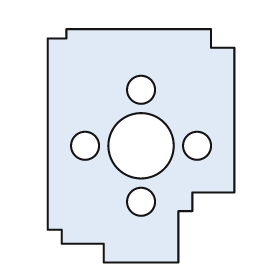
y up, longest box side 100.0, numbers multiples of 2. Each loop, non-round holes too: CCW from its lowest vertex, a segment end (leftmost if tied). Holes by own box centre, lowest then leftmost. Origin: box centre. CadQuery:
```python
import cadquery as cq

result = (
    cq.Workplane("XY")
    .moveTo(-16.0, -50.0)
    .lineTo(16.0, -50.0)
    .lineTo(16.0, -28.0)
    .lineTo(22.0, -28.0)
    .lineTo(22.0, -20.0)
    .lineTo(40.0, -20.0)
    .lineTo(40.0, 42.0)
    .lineTo(30.0, 42.0)
    .lineTo(30.0, 50.0)
    .lineTo(-32.0, 50.0)
    .lineTo(-32.0, 46.0)
    .lineTo(-40.0, 46.0)
    .lineTo(-40.0, -36.0)
    .lineTo(-34.0, -36.0)
    .lineTo(-34.0, -42.0)
    .lineTo(-16.0, -42.0)
    .close()
    .moveTo(0.0, -24.0)
    .circle(6.0)
    .moveTo(-24.0, 0.0)
    .circle(6.0)
    .moveTo(0.0, 0.0)
    .circle(14.0)
    .moveTo(24.0, 0.0)
    .circle(6.0)
    .moveTo(0.0, 24.0)
    .circle(6.0)
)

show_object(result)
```